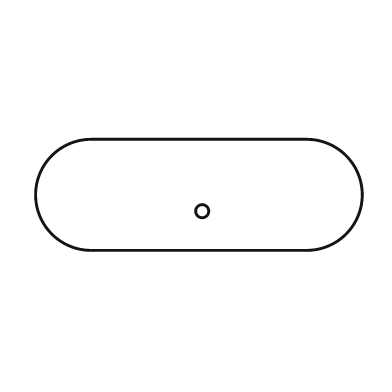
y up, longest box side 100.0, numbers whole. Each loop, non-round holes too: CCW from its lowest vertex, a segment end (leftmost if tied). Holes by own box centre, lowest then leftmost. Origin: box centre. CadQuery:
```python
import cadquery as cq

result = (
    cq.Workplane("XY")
    .moveTo(-33.0, -17.0)
    .lineTo(33.0, -17.0)
    .threePointArc((50.0, 0.0), (33.0, 17.0))
    .lineTo(-33.0, 17.0)
    .threePointArc((-50.0, 0.0), (-33.0, -17.0))
    .close()
    .moveTo(1.0, -5.0)
    .circle(2.0)
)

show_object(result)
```